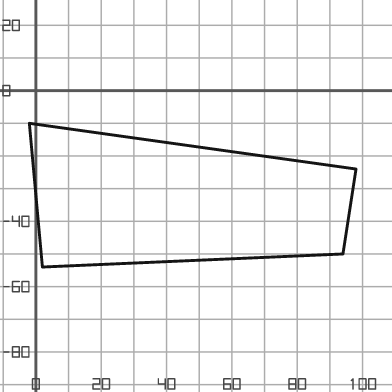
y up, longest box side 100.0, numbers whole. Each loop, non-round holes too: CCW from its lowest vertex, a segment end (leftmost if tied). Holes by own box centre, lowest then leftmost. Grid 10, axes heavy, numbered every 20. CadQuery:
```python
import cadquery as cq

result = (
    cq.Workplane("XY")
    .moveTo(2.0, -54.0)
    .lineTo(94.0, -50.0)
    .lineTo(98.0, -24.0)
    .lineTo(-2.0, -10.0)
    .close()
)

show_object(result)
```